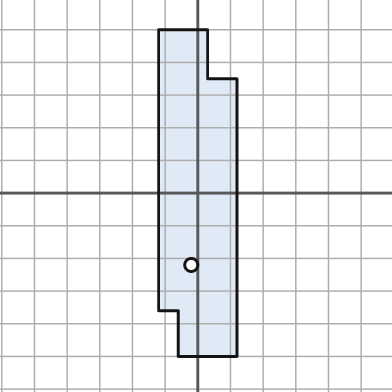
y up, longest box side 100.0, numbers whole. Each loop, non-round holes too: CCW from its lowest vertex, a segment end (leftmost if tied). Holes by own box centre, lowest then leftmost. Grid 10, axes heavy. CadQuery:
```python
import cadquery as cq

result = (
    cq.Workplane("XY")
    .moveTo(-6.0, -50.0)
    .lineTo(12.0, -50.0)
    .lineTo(12.0, 35.0)
    .lineTo(3.0, 35.0)
    .lineTo(3.0, 50.0)
    .lineTo(-12.0, 50.0)
    .lineTo(-12.0, -36.0)
    .lineTo(-6.0, -36.0)
    .close()
    .moveTo(-2.0, -22.0)
    .circle(2.0)
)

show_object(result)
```